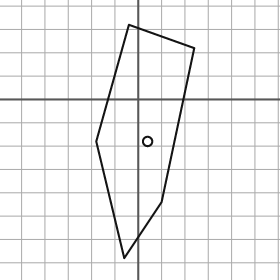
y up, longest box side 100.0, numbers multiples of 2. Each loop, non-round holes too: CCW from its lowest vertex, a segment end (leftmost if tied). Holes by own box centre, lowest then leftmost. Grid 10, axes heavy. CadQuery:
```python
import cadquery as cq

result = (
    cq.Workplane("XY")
    .moveTo(-6.0, -68.0)
    .lineTo(10.0, -44.0)
    .lineTo(24.0, 22.0)
    .lineTo(-4.0, 32.0)
    .lineTo(-18.0, -18.0)
    .close()
    .moveTo(4.0, -18.0)
    .circle(2.0)
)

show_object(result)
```